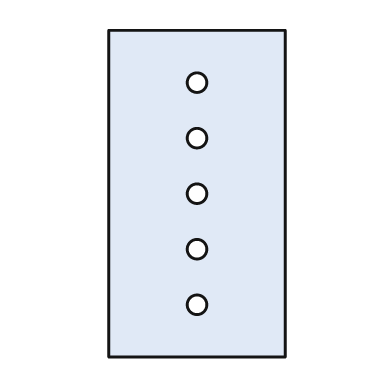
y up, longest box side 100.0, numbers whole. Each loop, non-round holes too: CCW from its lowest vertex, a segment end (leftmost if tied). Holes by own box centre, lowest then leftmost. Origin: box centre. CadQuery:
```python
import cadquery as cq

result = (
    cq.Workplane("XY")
    .moveTo(-27.0, -50.0)
    .lineTo(27.0, -50.0)
    .lineTo(27.0, 50.0)
    .lineTo(-27.0, 50.0)
    .close()
    .moveTo(0.0, -34.0)
    .circle(3.0)
    .moveTo(0.0, -17.0)
    .circle(3.0)
    .moveTo(0.0, 0.0)
    .circle(3.0)
    .moveTo(0.0, 17.0)
    .circle(3.0)
    .moveTo(0.0, 34.0)
    .circle(3.0)
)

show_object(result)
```